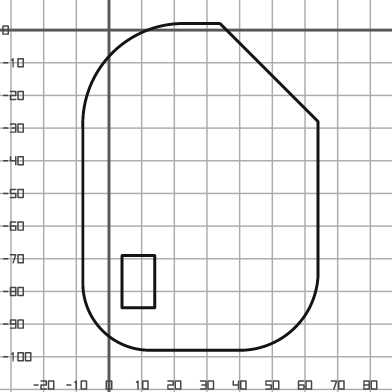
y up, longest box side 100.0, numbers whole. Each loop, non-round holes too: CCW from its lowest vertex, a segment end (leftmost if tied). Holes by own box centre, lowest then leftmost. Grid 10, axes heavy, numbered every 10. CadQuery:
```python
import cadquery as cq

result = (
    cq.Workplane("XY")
    .moveTo(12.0, -98.0)
    .lineTo(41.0, -98.0)
    .threePointArc((57.0, -91.0), (64.0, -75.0))
    .lineTo(64.0, -28.0)
    .lineTo(34.0, 2.0)
    .lineTo(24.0, 2.0)
    .threePointArc((1.0, -7.0), (-8.0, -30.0))
    .lineTo(-8.0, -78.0)
    .threePointArc((-2.0, -92.0), (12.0, -98.0))
    .close()
    .moveTo(4.0, -85.0)
    .lineTo(14.0, -85.0)
    .lineTo(14.0, -69.0)
    .lineTo(4.0, -69.0)
    .close()
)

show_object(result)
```